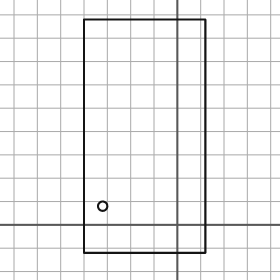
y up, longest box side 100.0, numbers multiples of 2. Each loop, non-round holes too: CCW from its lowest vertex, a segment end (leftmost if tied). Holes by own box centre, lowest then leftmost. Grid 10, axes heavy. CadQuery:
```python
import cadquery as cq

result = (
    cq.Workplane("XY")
    .moveTo(-40.0, -12.0)
    .lineTo(12.0, -12.0)
    .lineTo(12.0, 88.0)
    .lineTo(-40.0, 88.0)
    .close()
    .moveTo(-32.0, 8.0)
    .circle(2.0)
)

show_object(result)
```